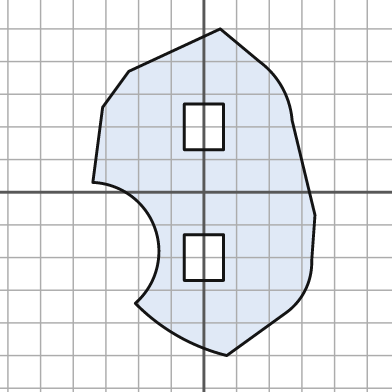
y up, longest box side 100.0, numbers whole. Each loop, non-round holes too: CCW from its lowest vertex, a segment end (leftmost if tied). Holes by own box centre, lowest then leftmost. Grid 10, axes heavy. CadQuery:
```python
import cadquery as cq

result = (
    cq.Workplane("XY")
    .moveTo(7.0, -50.0)
    .lineTo(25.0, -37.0)
    .threePointArc((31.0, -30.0), (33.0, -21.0))
    .lineTo(34.0, -7.0)
    .lineTo(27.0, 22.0)
    .threePointArc((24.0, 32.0), (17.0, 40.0))
    .lineTo(5.0, 50.0)
    .lineTo(-23.0, 37.0)
    .lineTo(-31.0, 26.0)
    .lineTo(-34.0, 3.0)
    .threePointArc((-15.0, -11.0), (-21.0, -34.0))
    .threePointArc((-8.0, -44.0), (7.0, -50.0))
    .close()
    .moveTo(-6.0, -27.0)
    .lineTo(6.0, -27.0)
    .lineTo(6.0, -13.0)
    .lineTo(-6.0, -13.0)
    .close()
    .moveTo(-6.0, 13.0)
    .lineTo(6.0, 13.0)
    .lineTo(6.0, 27.0)
    .lineTo(-6.0, 27.0)
    .close()
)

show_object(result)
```